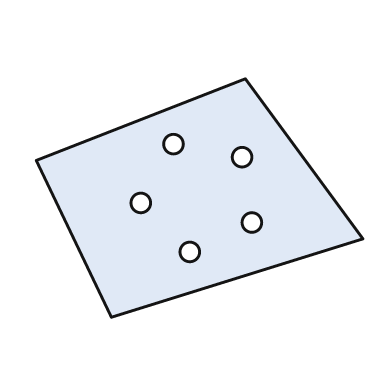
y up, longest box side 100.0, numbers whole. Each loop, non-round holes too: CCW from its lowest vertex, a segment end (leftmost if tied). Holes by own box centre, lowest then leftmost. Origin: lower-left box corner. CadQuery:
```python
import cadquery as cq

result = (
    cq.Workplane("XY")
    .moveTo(23.0, 0.0)
    .lineTo(100.0, 24.0)
    .lineTo(64.0, 73.0)
    .lineTo(0.0, 48.0)
    .close()
    .moveTo(47.0, 20.0)
    .circle(3.0)
    .moveTo(66.0, 29.0)
    .circle(3.0)
    .moveTo(32.0, 35.0)
    .circle(3.0)
    .moveTo(63.0, 49.0)
    .circle(3.0)
    .moveTo(42.0, 53.0)
    .circle(3.0)
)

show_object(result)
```